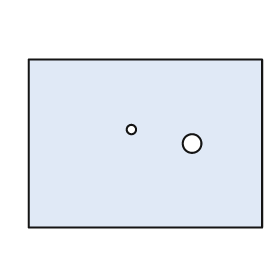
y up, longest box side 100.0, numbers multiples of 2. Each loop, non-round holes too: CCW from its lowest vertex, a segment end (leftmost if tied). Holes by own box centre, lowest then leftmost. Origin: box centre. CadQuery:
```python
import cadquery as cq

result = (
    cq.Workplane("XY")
    .moveTo(-50.0, -36.0)
    .lineTo(50.0, -36.0)
    .lineTo(50.0, 36.0)
    .lineTo(-50.0, 36.0)
    .close()
    .moveTo(20.0, 0.0)
    .circle(4.0)
    .moveTo(-6.0, 6.0)
    .circle(2.0)
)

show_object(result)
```